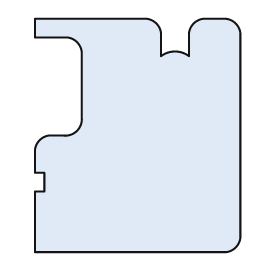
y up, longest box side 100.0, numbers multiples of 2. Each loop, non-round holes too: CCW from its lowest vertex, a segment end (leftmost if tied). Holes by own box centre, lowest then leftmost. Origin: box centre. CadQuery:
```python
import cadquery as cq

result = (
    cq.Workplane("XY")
    .moveTo(-44.0, -50.0)
    .lineTo(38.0, -50.0)
    .threePointArc((42.0, -48.0), (44.0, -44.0))
    .lineTo(44.0, 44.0)
    .threePointArc((42.0, 48.0), (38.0, 50.0))
    .lineTo(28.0, 50.0)
    .threePointArc((24.0, 48.0), (22.0, 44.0))
    .lineTo(22.0, 34.0)
    .threePointArc((16.0, 36.0), (10.0, 34.0))
    .lineTo(10.0, 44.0)
    .threePointArc((8.0, 48.0), (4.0, 50.0))
    .lineTo(-44.0, 50.0)
    .lineTo(-44.0, 42.0)
    .lineTo(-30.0, 42.0)
    .threePointArc((-26.0, 40.0), (-24.0, 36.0))
    .lineTo(-24.0, 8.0)
    .threePointArc((-26.0, 2.0), (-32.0, 0.0))
    .lineTo(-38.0, 0.0)
    .threePointArc((-42.0, -2.0), (-44.0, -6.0))
    .lineTo(-44.0, -16.0)
    .lineTo(-40.0, -16.0)
    .lineTo(-40.0, -24.0)
    .lineTo(-44.0, -24.0)
    .close()
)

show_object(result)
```